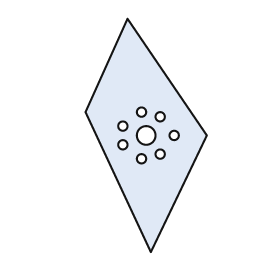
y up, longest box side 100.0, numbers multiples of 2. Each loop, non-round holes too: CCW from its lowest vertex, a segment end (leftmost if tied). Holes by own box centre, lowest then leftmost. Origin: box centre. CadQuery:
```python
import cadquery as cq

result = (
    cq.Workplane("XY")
    .moveTo(2.0, -50.0)
    .lineTo(26.0, 0.0)
    .lineTo(-8.0, 50.0)
    .lineTo(-26.0, 10.0)
    .close()
    .moveTo(-2.0, -10.0)
    .circle(2.0)
    .moveTo(6.0, -8.0)
    .circle(2.0)
    .moveTo(-10.0, -4.0)
    .circle(2.0)
    .moveTo(0.0, 0.0)
    .circle(4.0)
    .moveTo(12.0, 0.0)
    .circle(2.0)
    .moveTo(-10.0, 4.0)
    .circle(2.0)
    .moveTo(6.0, 8.0)
    .circle(2.0)
    .moveTo(-2.0, 10.0)
    .circle(2.0)
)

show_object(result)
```